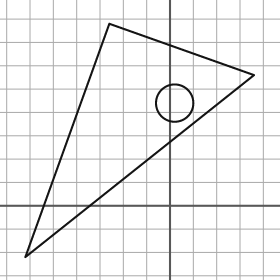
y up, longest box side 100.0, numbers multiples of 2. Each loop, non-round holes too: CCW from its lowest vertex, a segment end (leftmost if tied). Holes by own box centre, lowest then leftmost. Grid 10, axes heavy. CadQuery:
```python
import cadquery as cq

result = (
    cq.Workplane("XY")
    .moveTo(-62.0, -22.0)
    .lineTo(36.0, 56.0)
    .lineTo(-26.0, 78.0)
    .close()
    .moveTo(2.0, 44.0)
    .circle(8.0)
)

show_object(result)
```